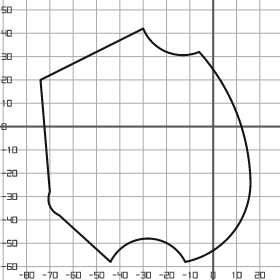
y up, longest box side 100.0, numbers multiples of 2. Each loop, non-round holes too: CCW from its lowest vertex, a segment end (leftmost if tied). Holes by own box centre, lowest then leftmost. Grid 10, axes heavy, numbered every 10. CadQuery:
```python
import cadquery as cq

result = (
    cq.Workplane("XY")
    .moveTo(-44.0, -58.0)
    .threePointArc((-28.0, -48.0), (-12.0, -58.0))
    .threePointArc((8.0, -46.0), (16.0, -24.0))
    .threePointArc((10.0, 6.0), (-6.0, 32.0))
    .threePointArc((-20.0, 32.0), (-30.0, 42.0))
    .lineTo(-74.0, 20.0)
    .lineTo(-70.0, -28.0)
    .threePointArc((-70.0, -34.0), (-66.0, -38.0))
    .close()
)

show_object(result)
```